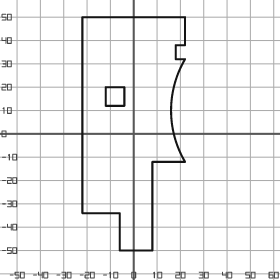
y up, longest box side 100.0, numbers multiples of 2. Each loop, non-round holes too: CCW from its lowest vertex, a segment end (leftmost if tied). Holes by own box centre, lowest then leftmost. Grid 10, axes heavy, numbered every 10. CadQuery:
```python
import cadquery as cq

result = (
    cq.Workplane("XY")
    .moveTo(-6.0, -50.0)
    .lineTo(8.0, -50.0)
    .lineTo(8.0, -12.0)
    .lineTo(22.0, -12.0)
    .threePointArc((16.0, 10.0), (22.0, 32.0))
    .lineTo(18.0, 32.0)
    .lineTo(18.0, 38.0)
    .lineTo(22.0, 38.0)
    .lineTo(22.0, 50.0)
    .lineTo(-22.0, 50.0)
    .lineTo(-22.0, -34.0)
    .lineTo(-6.0, -34.0)
    .close()
    .moveTo(-12.0, 12.0)
    .lineTo(-4.0, 12.0)
    .lineTo(-4.0, 20.0)
    .lineTo(-12.0, 20.0)
    .close()
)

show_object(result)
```